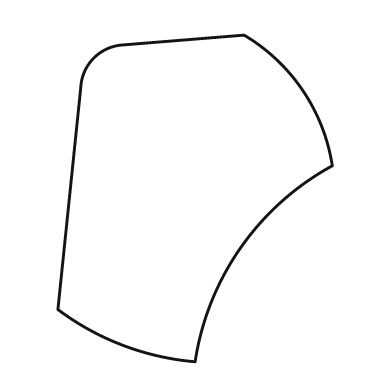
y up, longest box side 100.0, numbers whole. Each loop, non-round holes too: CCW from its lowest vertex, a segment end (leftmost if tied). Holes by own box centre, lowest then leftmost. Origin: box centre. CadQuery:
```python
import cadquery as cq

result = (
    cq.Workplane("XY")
    .moveTo(0.0, -50.0)
    .threePointArc((14.0, -15.0), (42.0, 10.0))
    .threePointArc((33.0, 33.0), (15.0, 50.0))
    .lineTo(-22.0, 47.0)
    .threePointArc((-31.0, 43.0), (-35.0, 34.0))
    .lineTo(-42.0, -34.0)
    .threePointArc((-22.0, -45.0), (0.0, -50.0))
    .close()
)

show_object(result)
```